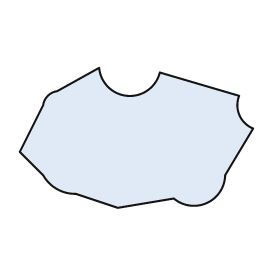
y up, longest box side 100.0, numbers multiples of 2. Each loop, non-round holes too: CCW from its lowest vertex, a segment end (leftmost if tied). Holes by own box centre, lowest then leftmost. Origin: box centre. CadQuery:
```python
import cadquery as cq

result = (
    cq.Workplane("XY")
    .moveTo(-8.0, -30.0)
    .lineTo(16.0, -26.0)
    .threePointArc((30.0, -28.0), (38.0, -16.0))
    .lineTo(50.0, 4.0)
    .threePointArc((44.0, 10.0), (44.0, 18.0))
    .lineTo(10.0, 28.0)
    .threePointArc((-4.0, 18.0), (-16.0, 30.0))
    .lineTo(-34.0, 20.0)
    .threePointArc((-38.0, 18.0), (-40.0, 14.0))
    .lineTo(-50.0, -6.0)
    .lineTo(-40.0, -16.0)
    .threePointArc((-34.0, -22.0), (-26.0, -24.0))
    .close()
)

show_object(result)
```